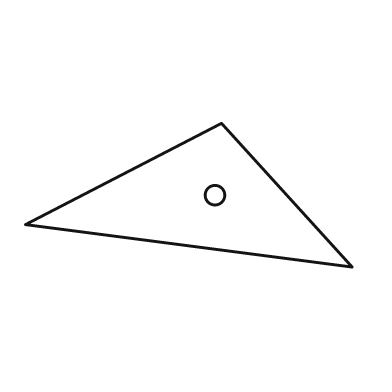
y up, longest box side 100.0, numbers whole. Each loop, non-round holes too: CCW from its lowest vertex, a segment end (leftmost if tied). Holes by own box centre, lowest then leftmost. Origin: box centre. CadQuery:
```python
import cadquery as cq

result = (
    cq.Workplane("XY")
    .moveTo(50.0, -22.0)
    .lineTo(10.0, 22.0)
    .lineTo(-50.0, -9.0)
    .close()
    .moveTo(8.0, 0.0)
    .circle(3.0)
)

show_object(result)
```